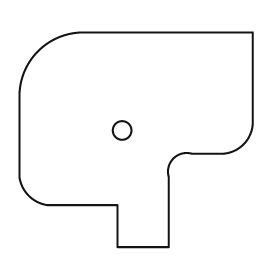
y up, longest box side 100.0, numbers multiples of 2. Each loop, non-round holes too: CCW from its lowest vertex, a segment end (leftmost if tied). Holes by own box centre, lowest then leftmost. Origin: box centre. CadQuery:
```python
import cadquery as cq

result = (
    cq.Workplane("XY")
    .moveTo(-8.0, -46.0)
    .lineTo(14.0, -46.0)
    .lineTo(14.0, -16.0)
    .threePointArc((16.0, -8.0), (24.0, -6.0))
    .lineTo(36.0, -6.0)
    .threePointArc((46.0, -2.0), (50.0, 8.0))
    .lineTo(50.0, 46.0)
    .lineTo(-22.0, 46.0)
    .threePointArc((-42.0, 38.0), (-50.0, 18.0))
    .lineTo(-50.0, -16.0)
    .threePointArc((-46.0, -24.0), (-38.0, -28.0))
    .lineTo(-8.0, -28.0)
    .close()
    .moveTo(-6.0, 4.0)
    .circle(4.0)
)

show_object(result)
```